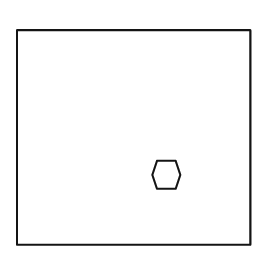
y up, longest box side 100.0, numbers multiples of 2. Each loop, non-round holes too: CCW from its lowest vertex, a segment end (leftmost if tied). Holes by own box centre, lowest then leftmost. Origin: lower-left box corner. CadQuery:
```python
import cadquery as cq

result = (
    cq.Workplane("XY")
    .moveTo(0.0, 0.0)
    .lineTo(100.0, 0.0)
    .lineTo(100.0, 92.0)
    .lineTo(0.0, 92.0)
    .close()
    .moveTo(60.0, 24.0)
    .lineTo(68.0, 24.0)
    .lineTo(70.0, 30.0)
    .lineTo(68.0, 36.0)
    .lineTo(60.0, 36.0)
    .lineTo(58.0, 30.0)
    .close()
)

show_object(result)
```